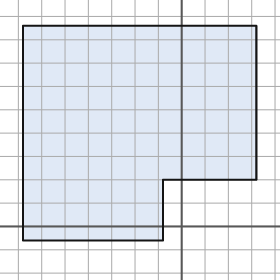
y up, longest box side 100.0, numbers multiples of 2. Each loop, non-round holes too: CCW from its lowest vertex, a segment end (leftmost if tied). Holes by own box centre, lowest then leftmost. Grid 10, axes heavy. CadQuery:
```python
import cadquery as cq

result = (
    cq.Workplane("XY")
    .moveTo(-68.0, -6.0)
    .lineTo(-8.0, -6.0)
    .lineTo(-8.0, 20.0)
    .lineTo(32.0, 20.0)
    .lineTo(32.0, 86.0)
    .lineTo(-68.0, 86.0)
    .close()
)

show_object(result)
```